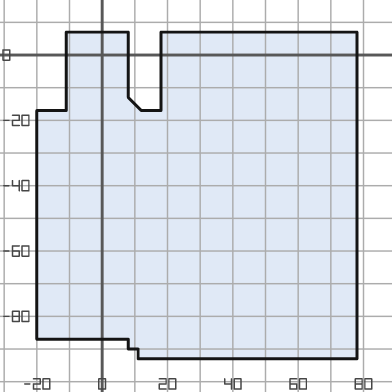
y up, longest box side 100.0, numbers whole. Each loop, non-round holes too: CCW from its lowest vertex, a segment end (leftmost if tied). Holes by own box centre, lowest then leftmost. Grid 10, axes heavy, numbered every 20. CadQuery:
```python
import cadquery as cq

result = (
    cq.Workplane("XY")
    .moveTo(11.0, -93.0)
    .lineTo(78.0, -93.0)
    .lineTo(78.0, 7.0)
    .lineTo(18.0, 7.0)
    .lineTo(18.0, -17.0)
    .lineTo(12.0, -17.0)
    .lineTo(8.0, -13.0)
    .lineTo(8.0, 7.0)
    .lineTo(-11.0, 7.0)
    .lineTo(-11.0, -17.0)
    .lineTo(-20.0, -17.0)
    .lineTo(-20.0, -87.0)
    .lineTo(8.0, -87.0)
    .lineTo(8.0, -90.0)
    .lineTo(11.0, -90.0)
    .close()
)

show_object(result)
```